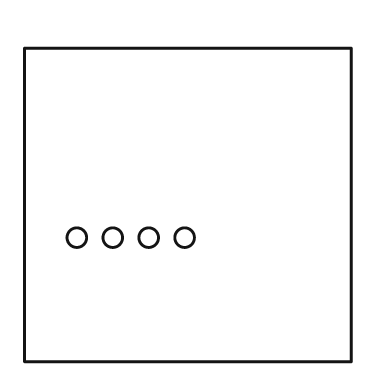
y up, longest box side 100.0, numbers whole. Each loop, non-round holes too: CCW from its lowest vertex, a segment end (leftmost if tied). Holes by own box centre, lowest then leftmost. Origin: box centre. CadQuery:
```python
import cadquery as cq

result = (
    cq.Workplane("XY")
    .moveTo(-50.0, -48.0)
    .lineTo(50.0, -48.0)
    .lineTo(50.0, 48.0)
    .lineTo(-50.0, 48.0)
    .close()
    .moveTo(-34.0, -10.0)
    .circle(3.0)
    .moveTo(-23.0, -10.0)
    .circle(3.0)
    .moveTo(-12.0, -10.0)
    .circle(3.0)
    .moveTo(-1.0, -10.0)
    .circle(3.0)
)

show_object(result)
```